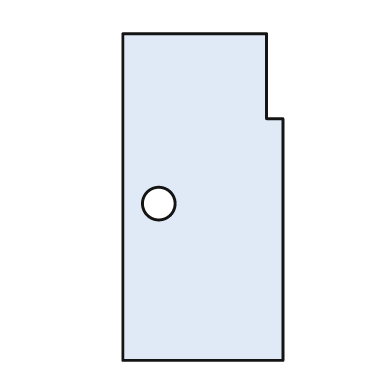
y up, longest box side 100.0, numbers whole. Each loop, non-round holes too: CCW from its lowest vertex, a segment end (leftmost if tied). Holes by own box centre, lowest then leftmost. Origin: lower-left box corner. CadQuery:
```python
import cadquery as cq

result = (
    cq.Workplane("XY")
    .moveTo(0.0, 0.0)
    .lineTo(49.0, 0.0)
    .lineTo(49.0, 74.0)
    .lineTo(44.0, 74.0)
    .lineTo(44.0, 100.0)
    .lineTo(0.0, 100.0)
    .close()
    .moveTo(11.0, 48.0)
    .circle(5.0)
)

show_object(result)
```